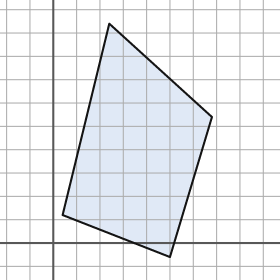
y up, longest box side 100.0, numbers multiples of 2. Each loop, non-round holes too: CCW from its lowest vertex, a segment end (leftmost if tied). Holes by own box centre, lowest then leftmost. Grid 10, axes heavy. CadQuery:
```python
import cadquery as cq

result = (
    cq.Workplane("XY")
    .moveTo(50.0, -6.0)
    .lineTo(68.0, 54.0)
    .lineTo(24.0, 94.0)
    .lineTo(4.0, 12.0)
    .close()
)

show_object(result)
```